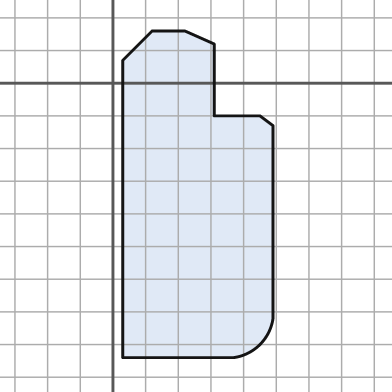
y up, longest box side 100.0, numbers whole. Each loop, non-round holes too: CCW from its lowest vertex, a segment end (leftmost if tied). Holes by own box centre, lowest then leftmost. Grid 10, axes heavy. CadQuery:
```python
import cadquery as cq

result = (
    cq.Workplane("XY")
    .moveTo(3.0, -84.0)
    .lineTo(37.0, -84.0)
    .threePointArc((45.0, -80.0), (49.0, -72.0))
    .lineTo(49.0, -13.0)
    .lineTo(45.0, -10.0)
    .lineTo(31.0, -10.0)
    .lineTo(31.0, 12.0)
    .lineTo(22.0, 16.0)
    .lineTo(12.0, 16.0)
    .lineTo(3.0, 7.0)
    .close()
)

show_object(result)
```